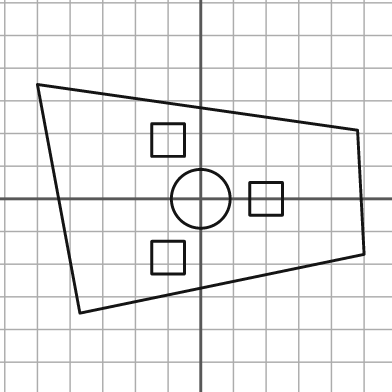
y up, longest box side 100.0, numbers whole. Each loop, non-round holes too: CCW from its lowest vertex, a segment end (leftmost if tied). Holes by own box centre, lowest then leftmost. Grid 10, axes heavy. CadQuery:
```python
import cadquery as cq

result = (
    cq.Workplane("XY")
    .moveTo(-37.0, -35.0)
    .lineTo(50.0, -17.0)
    .lineTo(48.0, 21.0)
    .lineTo(-50.0, 35.0)
    .close()
    .moveTo(-15.0, -23.0)
    .lineTo(-5.0, -23.0)
    .lineTo(-5.0, -13.0)
    .lineTo(-15.0, -13.0)
    .close()
    .moveTo(0.0, 0.0)
    .circle(9.0)
    .moveTo(15.0, -5.0)
    .lineTo(25.0, -5.0)
    .lineTo(25.0, 5.0)
    .lineTo(15.0, 5.0)
    .close()
    .moveTo(-15.0, 13.0)
    .lineTo(-5.0, 13.0)
    .lineTo(-5.0, 23.0)
    .lineTo(-15.0, 23.0)
    .close()
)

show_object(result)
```